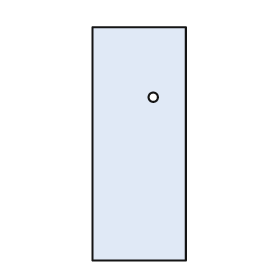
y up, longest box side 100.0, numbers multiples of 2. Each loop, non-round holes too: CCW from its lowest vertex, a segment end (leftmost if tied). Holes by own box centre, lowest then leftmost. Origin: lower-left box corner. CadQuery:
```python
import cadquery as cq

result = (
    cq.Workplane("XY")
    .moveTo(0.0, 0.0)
    .lineTo(40.0, 0.0)
    .lineTo(40.0, 100.0)
    .lineTo(0.0, 100.0)
    .close()
    .moveTo(26.0, 70.0)
    .circle(2.0)
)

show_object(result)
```